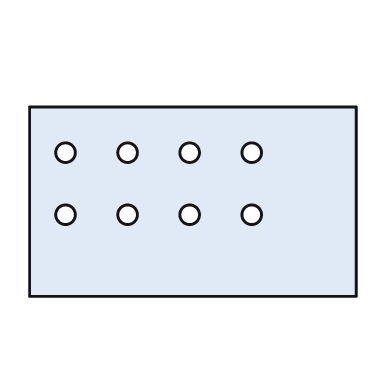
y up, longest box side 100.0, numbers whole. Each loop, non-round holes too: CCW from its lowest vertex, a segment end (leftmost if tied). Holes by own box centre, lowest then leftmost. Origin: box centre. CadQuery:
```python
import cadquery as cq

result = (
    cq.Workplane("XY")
    .moveTo(-50.0, -29.0)
    .lineTo(50.0, -29.0)
    .lineTo(50.0, 29.0)
    .lineTo(-50.0, 29.0)
    .close()
    .moveTo(-39.0, -4.0)
    .circle(3.0)
    .moveTo(-20.0, -4.0)
    .circle(3.0)
    .moveTo(-1.0, -4.0)
    .circle(3.0)
    .moveTo(18.0, -4.0)
    .circle(3.0)
    .moveTo(-39.0, 15.0)
    .circle(3.0)
    .moveTo(-20.0, 15.0)
    .circle(3.0)
    .moveTo(-1.0, 15.0)
    .circle(3.0)
    .moveTo(18.0, 15.0)
    .circle(3.0)
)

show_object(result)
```